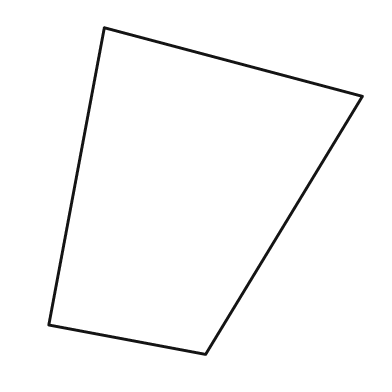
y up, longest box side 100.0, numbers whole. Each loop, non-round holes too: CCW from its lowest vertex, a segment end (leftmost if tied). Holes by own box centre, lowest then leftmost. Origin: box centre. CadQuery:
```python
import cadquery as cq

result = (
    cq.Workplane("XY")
    .moveTo(0.0, -50.0)
    .lineTo(48.0, 29.0)
    .lineTo(-31.0, 50.0)
    .lineTo(-48.0, -41.0)
    .close()
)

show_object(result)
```